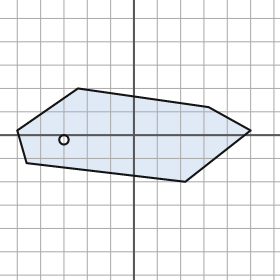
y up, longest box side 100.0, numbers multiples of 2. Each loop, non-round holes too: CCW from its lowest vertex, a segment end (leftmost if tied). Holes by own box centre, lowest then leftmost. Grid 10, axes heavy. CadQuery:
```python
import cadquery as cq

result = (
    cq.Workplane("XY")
    .moveTo(22.0, -20.0)
    .lineTo(50.0, 2.0)
    .lineTo(32.0, 12.0)
    .lineTo(-24.0, 20.0)
    .lineTo(-50.0, 2.0)
    .lineTo(-46.0, -12.0)
    .close()
    .moveTo(-30.0, -2.0)
    .circle(2.0)
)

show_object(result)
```